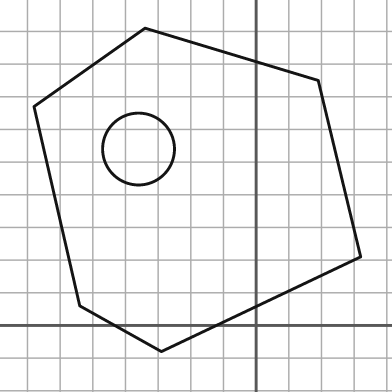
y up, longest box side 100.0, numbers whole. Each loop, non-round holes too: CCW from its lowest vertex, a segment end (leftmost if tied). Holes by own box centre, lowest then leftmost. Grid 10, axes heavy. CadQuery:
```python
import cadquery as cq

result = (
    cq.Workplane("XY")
    .moveTo(-29.0, -8.0)
    .lineTo(32.0, 21.0)
    .lineTo(19.0, 75.0)
    .lineTo(-34.0, 91.0)
    .lineTo(-68.0, 67.0)
    .lineTo(-54.0, 6.0)
    .close()
    .moveTo(-36.0, 54.0)
    .circle(11.0)
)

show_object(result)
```